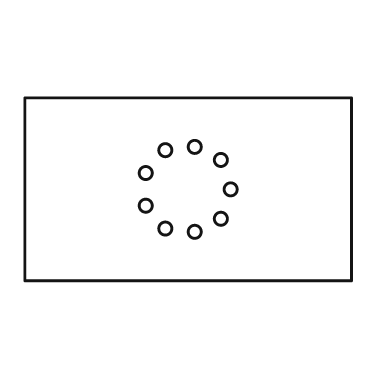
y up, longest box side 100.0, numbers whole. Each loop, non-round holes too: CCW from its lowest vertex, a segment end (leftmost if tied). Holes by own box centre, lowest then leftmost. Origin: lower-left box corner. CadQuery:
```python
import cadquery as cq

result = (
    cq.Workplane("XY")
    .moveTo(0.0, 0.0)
    .lineTo(100.0, 0.0)
    .lineTo(100.0, 56.0)
    .lineTo(0.0, 56.0)
    .close()
    .moveTo(52.0, 15.0)
    .circle(2.0)
    .moveTo(43.0, 16.0)
    .circle(2.0)
    .moveTo(60.0, 19.0)
    .circle(2.0)
    .moveTo(37.0, 23.0)
    .circle(2.0)
    .moveTo(63.0, 28.0)
    .circle(2.0)
    .moveTo(37.0, 33.0)
    .circle(2.0)
    .moveTo(60.0, 37.0)
    .circle(2.0)
    .moveTo(43.0, 40.0)
    .circle(2.0)
    .moveTo(52.0, 41.0)
    .circle(2.0)
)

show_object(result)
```